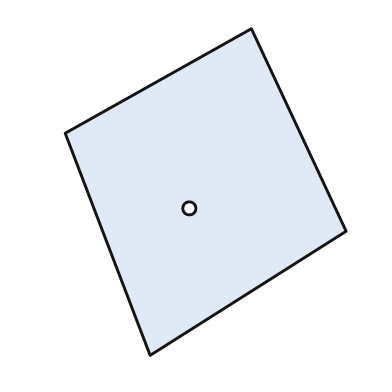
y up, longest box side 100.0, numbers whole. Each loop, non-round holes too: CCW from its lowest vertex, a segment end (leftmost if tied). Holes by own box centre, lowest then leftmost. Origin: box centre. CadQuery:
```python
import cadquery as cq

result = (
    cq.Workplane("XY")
    .moveTo(-17.0, -50.0)
    .lineTo(43.0, -12.0)
    .lineTo(14.0, 50.0)
    .lineTo(-43.0, 18.0)
    .close()
    .moveTo(-5.0, -5.0)
    .circle(2.0)
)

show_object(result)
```